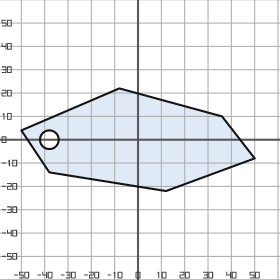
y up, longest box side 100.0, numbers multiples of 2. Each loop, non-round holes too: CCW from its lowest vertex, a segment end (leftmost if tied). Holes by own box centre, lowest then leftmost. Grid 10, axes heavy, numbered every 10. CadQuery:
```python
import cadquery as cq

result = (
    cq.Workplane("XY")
    .moveTo(12.0, -22.0)
    .lineTo(50.0, -8.0)
    .lineTo(36.0, 10.0)
    .lineTo(-8.0, 22.0)
    .lineTo(-50.0, 4.0)
    .lineTo(-38.0, -14.0)
    .close()
    .moveTo(-38.0, 0.0)
    .circle(4.0)
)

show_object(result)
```